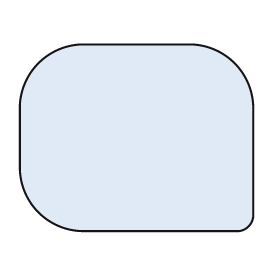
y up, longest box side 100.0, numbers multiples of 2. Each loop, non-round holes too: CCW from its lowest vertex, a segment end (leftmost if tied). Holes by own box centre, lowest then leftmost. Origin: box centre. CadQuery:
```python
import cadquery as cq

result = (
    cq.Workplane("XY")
    .moveTo(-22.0, -40.0)
    .lineTo(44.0, -40.0)
    .threePointArc((48.0, -38.0), (50.0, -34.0))
    .lineTo(50.0, 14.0)
    .threePointArc((42.0, 32.0), (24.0, 40.0))
    .lineTo(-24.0, 40.0)
    .threePointArc((-42.0, 32.0), (-50.0, 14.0))
    .lineTo(-50.0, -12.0)
    .threePointArc((-42.0, -32.0), (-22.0, -40.0))
    .close()
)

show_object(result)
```